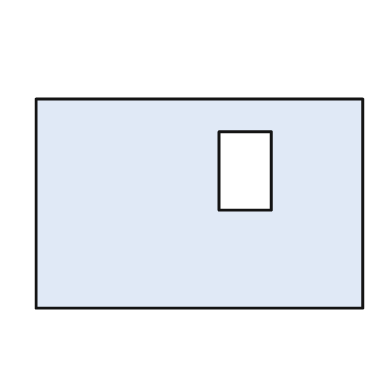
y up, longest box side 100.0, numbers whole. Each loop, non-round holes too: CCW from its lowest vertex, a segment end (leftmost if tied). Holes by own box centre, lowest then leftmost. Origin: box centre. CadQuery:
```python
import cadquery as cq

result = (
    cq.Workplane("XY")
    .moveTo(-50.0, -32.0)
    .lineTo(50.0, -32.0)
    .lineTo(50.0, 32.0)
    .lineTo(-50.0, 32.0)
    .close()
    .moveTo(6.0, -2.0)
    .lineTo(22.0, -2.0)
    .lineTo(22.0, 22.0)
    .lineTo(6.0, 22.0)
    .close()
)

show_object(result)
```